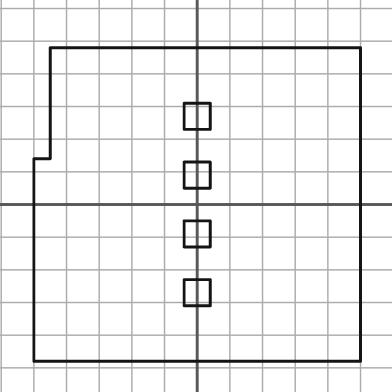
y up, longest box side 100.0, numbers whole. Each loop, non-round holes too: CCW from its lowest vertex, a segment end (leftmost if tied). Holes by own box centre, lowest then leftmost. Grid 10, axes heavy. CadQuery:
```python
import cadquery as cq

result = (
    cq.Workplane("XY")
    .moveTo(-50.0, -48.0)
    .lineTo(50.0, -48.0)
    .lineTo(50.0, 48.0)
    .lineTo(-45.0, 48.0)
    .lineTo(-45.0, 14.0)
    .lineTo(-50.0, 14.0)
    .close()
    .moveTo(-4.0, -31.0)
    .lineTo(4.0, -31.0)
    .lineTo(4.0, -23.0)
    .lineTo(-4.0, -23.0)
    .close()
    .moveTo(-4.0, -13.0)
    .lineTo(4.0, -13.0)
    .lineTo(4.0, -5.0)
    .lineTo(-4.0, -5.0)
    .close()
    .moveTo(-4.0, 5.0)
    .lineTo(4.0, 5.0)
    .lineTo(4.0, 13.0)
    .lineTo(-4.0, 13.0)
    .close()
    .moveTo(-4.0, 23.0)
    .lineTo(4.0, 23.0)
    .lineTo(4.0, 31.0)
    .lineTo(-4.0, 31.0)
    .close()
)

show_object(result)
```